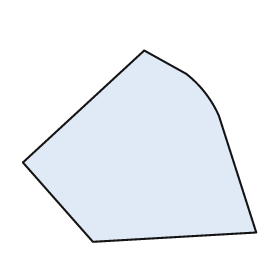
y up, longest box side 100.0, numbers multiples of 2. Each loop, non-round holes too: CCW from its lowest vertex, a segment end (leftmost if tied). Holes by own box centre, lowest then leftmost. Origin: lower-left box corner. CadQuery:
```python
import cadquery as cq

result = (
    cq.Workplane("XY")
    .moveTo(30.0, 0.0)
    .lineTo(100.0, 4.0)
    .lineTo(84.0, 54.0)
    .threePointArc((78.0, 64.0), (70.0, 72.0))
    .lineTo(52.0, 82.0)
    .lineTo(0.0, 34.0)
    .close()
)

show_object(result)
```